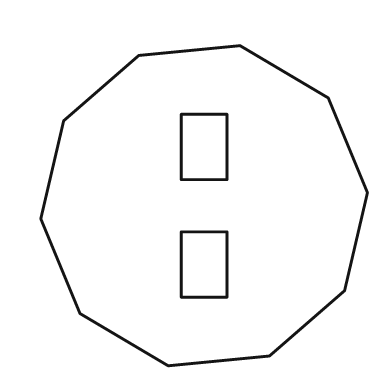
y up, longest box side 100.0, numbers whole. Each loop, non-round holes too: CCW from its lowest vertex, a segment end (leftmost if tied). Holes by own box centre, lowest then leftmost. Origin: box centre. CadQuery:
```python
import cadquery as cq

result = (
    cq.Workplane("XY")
    .moveTo(-11.0, -49.0)
    .lineTo(20.0, -46.0)
    .lineTo(43.0, -26.0)
    .lineTo(50.0, 4.0)
    .lineTo(38.0, 33.0)
    .lineTo(11.0, 49.0)
    .lineTo(-20.0, 46.0)
    .lineTo(-43.0, 26.0)
    .lineTo(-50.0, -4.0)
    .lineTo(-38.0, -33.0)
    .close()
    .moveTo(-7.0, -28.0)
    .lineTo(7.0, -28.0)
    .lineTo(7.0, -8.0)
    .lineTo(-7.0, -8.0)
    .close()
    .moveTo(-7.0, 8.0)
    .lineTo(7.0, 8.0)
    .lineTo(7.0, 28.0)
    .lineTo(-7.0, 28.0)
    .close()
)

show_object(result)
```